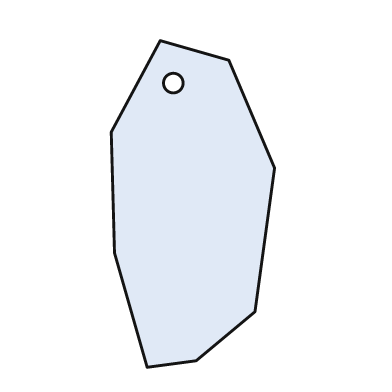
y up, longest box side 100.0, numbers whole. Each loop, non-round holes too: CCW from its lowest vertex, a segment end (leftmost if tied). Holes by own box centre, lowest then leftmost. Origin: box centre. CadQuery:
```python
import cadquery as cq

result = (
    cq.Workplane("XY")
    .moveTo(-14.0, -50.0)
    .lineTo(1.0, -48.0)
    .lineTo(19.0, -33.0)
    .lineTo(25.0, 11.0)
    .lineTo(11.0, 44.0)
    .lineTo(-10.0, 50.0)
    .lineTo(-25.0, 22.0)
    .lineTo(-24.0, -15.0)
    .close()
    .moveTo(-6.0, 37.0)
    .circle(3.0)
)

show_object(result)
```